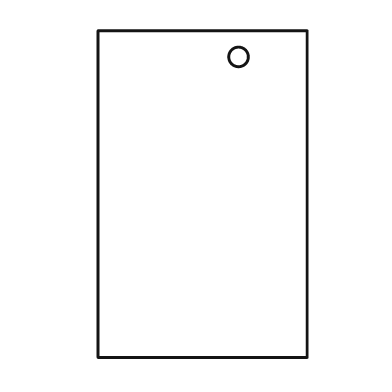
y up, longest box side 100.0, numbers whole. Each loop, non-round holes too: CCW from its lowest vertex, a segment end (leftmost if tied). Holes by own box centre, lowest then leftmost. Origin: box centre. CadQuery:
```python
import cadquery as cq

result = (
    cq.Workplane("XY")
    .moveTo(-32.0, -50.0)
    .lineTo(32.0, -50.0)
    .lineTo(32.0, 50.0)
    .lineTo(-32.0, 50.0)
    .close()
    .moveTo(11.0, 42.0)
    .circle(3.0)
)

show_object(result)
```